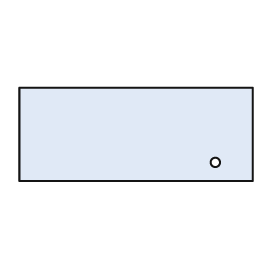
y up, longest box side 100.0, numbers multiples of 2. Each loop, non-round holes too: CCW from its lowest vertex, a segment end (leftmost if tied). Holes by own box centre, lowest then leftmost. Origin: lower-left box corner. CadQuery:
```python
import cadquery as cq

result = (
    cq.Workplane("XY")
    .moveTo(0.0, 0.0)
    .lineTo(100.0, 0.0)
    .lineTo(100.0, 40.0)
    .lineTo(0.0, 40.0)
    .close()
    .moveTo(84.0, 8.0)
    .circle(2.0)
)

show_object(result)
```